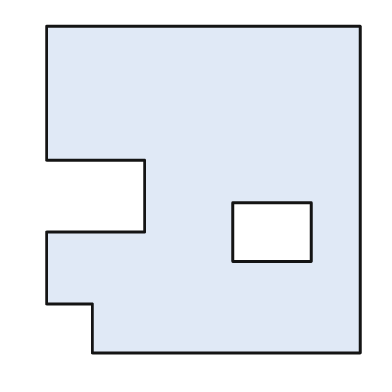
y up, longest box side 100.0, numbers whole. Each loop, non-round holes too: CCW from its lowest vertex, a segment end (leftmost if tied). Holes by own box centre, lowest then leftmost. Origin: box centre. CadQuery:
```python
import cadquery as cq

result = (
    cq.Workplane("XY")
    .moveTo(-34.0, -50.0)
    .lineTo(48.0, -50.0)
    .lineTo(48.0, 50.0)
    .lineTo(-48.0, 50.0)
    .lineTo(-48.0, 9.0)
    .lineTo(-18.0, 9.0)
    .lineTo(-18.0, -13.0)
    .lineTo(-48.0, -13.0)
    .lineTo(-48.0, -35.0)
    .lineTo(-34.0, -35.0)
    .close()
    .moveTo(9.0, -22.0)
    .lineTo(33.0, -22.0)
    .lineTo(33.0, -4.0)
    .lineTo(9.0, -4.0)
    .close()
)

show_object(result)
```